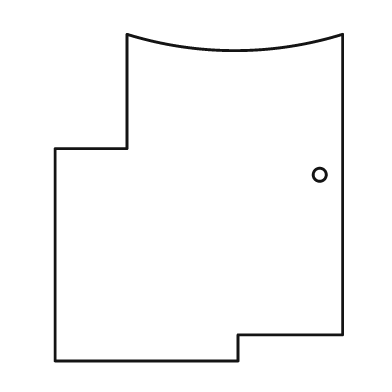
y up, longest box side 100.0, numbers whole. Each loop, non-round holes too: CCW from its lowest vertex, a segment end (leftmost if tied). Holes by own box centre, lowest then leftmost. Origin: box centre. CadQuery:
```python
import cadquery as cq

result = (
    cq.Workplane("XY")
    .moveTo(-44.0, -50.0)
    .lineTo(12.0, -50.0)
    .lineTo(12.0, -42.0)
    .lineTo(44.0, -42.0)
    .lineTo(44.0, 50.0)
    .threePointArc((11.0, 45.0), (-22.0, 50.0))
    .lineTo(-22.0, 15.0)
    .lineTo(-44.0, 15.0)
    .close()
    .moveTo(37.0, 7.0)
    .circle(2.0)
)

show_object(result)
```